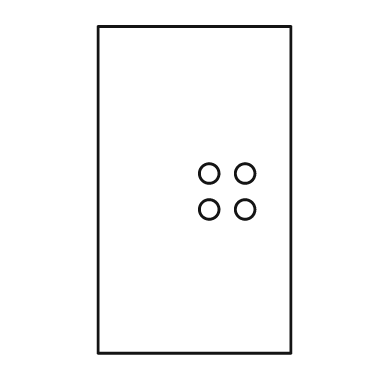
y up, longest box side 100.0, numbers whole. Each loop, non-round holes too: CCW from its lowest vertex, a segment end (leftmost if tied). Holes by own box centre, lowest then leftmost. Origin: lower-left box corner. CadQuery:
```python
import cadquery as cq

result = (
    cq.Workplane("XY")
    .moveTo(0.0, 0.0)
    .lineTo(59.0, 0.0)
    .lineTo(59.0, 100.0)
    .lineTo(0.0, 100.0)
    .close()
    .moveTo(34.0, 44.0)
    .circle(3.0)
    .moveTo(45.0, 44.0)
    .circle(3.0)
    .moveTo(34.0, 55.0)
    .circle(3.0)
    .moveTo(45.0, 55.0)
    .circle(3.0)
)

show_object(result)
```